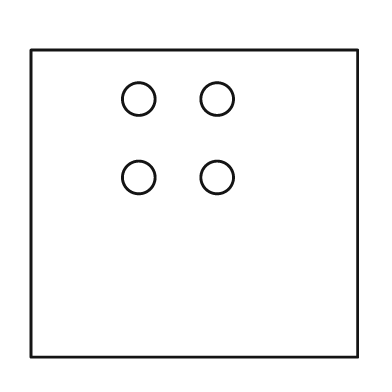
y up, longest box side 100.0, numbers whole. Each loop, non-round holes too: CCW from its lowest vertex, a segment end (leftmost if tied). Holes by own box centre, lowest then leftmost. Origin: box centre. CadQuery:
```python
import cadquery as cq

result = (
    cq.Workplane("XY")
    .moveTo(-50.0, -47.0)
    .lineTo(50.0, -47.0)
    .lineTo(50.0, 47.0)
    .lineTo(-50.0, 47.0)
    .close()
    .moveTo(-17.0, 8.0)
    .circle(5.0)
    .moveTo(7.0, 8.0)
    .circle(5.0)
    .moveTo(-17.0, 32.0)
    .circle(5.0)
    .moveTo(7.0, 32.0)
    .circle(5.0)
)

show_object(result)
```